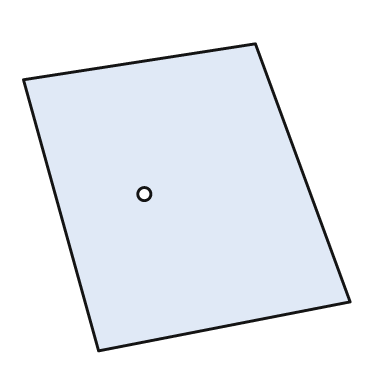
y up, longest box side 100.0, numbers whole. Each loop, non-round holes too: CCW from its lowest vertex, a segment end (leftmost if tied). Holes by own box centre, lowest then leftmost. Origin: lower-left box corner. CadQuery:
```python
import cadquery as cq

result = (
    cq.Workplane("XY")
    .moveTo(23.0, 0.0)
    .lineTo(100.0, 15.0)
    .lineTo(71.0, 94.0)
    .lineTo(0.0, 83.0)
    .close()
    .moveTo(37.0, 48.0)
    .circle(2.0)
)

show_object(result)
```